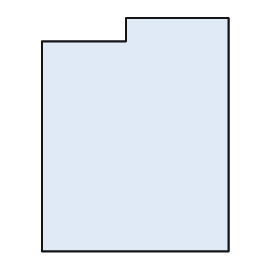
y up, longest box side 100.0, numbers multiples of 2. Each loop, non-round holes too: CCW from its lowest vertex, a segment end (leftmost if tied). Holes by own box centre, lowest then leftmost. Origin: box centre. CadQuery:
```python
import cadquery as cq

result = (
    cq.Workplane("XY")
    .moveTo(-40.0, -50.0)
    .lineTo(40.0, -50.0)
    .lineTo(40.0, 50.0)
    .lineTo(-4.0, 50.0)
    .lineTo(-4.0, 40.0)
    .lineTo(-40.0, 40.0)
    .close()
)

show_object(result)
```